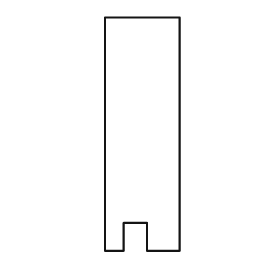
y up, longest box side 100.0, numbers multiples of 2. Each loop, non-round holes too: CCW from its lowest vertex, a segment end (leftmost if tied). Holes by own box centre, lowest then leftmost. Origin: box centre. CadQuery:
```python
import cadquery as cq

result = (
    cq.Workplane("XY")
    .moveTo(-16.0, -50.0)
    .lineTo(-8.0, -50.0)
    .lineTo(-8.0, -38.0)
    .lineTo(2.0, -38.0)
    .lineTo(2.0, -50.0)
    .lineTo(16.0, -50.0)
    .lineTo(16.0, 50.0)
    .lineTo(-16.0, 50.0)
    .close()
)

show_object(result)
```